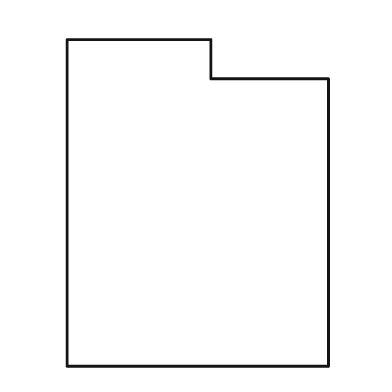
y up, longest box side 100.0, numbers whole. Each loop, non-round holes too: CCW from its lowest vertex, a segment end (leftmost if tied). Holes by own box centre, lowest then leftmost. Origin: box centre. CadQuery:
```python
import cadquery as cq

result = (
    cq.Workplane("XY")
    .moveTo(-40.0, -50.0)
    .lineTo(40.0, -50.0)
    .lineTo(40.0, 38.0)
    .lineTo(4.0, 38.0)
    .lineTo(4.0, 50.0)
    .lineTo(-40.0, 50.0)
    .close()
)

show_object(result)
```